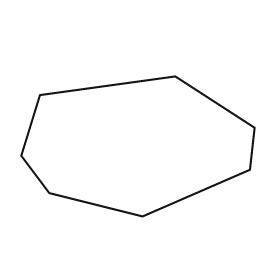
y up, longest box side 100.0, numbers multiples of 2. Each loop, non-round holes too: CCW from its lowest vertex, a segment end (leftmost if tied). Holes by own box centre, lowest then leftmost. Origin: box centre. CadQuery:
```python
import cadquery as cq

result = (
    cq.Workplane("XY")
    .moveTo(2.0, -30.0)
    .lineTo(48.0, -10.0)
    .lineTo(50.0, 8.0)
    .lineTo(16.0, 30.0)
    .lineTo(-42.0, 22.0)
    .lineTo(-50.0, -4.0)
    .lineTo(-38.0, -20.0)
    .close()
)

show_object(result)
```